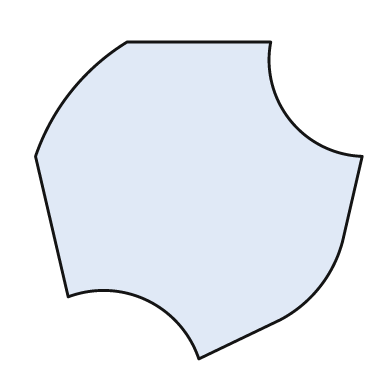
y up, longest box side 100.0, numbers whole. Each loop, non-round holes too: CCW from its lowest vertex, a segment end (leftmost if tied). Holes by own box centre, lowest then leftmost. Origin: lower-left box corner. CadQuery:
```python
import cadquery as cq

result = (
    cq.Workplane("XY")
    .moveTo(50.0, 0.0)
    .lineTo(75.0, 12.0)
    .threePointArc((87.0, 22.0), (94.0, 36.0))
    .lineTo(100.0, 62.0)
    .threePointArc((78.0, 73.0), (72.0, 97.0))
    .lineTo(28.0, 97.0)
    .threePointArc((11.0, 82.0), (0.0, 62.0))
    .lineTo(10.0, 19.0)
    .threePointArc((34.0, 18.0), (50.0, 0.0))
    .close()
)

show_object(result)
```